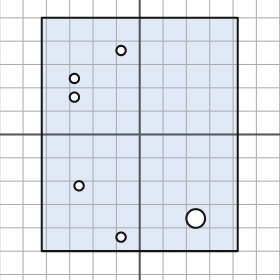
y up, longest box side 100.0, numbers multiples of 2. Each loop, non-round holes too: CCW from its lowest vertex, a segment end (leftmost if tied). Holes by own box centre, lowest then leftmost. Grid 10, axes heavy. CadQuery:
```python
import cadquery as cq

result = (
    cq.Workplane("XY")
    .moveTo(-42.0, -50.0)
    .lineTo(42.0, -50.0)
    .lineTo(42.0, 50.0)
    .lineTo(-42.0, 50.0)
    .close()
    .moveTo(-8.0, -44.0)
    .circle(2.0)
    .moveTo(24.0, -36.0)
    .circle(4.0)
    .moveTo(-26.0, -22.0)
    .circle(2.0)
    .moveTo(-28.0, 16.0)
    .circle(2.0)
    .moveTo(-28.0, 24.0)
    .circle(2.0)
    .moveTo(-8.0, 36.0)
    .circle(2.0)
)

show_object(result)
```